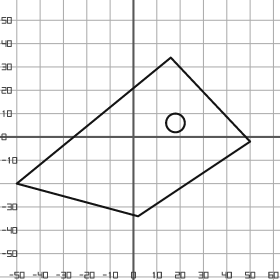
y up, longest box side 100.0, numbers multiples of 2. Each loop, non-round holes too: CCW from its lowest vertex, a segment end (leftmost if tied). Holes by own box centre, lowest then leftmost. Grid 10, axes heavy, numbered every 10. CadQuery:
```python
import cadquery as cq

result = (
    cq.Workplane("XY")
    .moveTo(2.0, -34.0)
    .lineTo(50.0, -2.0)
    .lineTo(16.0, 34.0)
    .lineTo(-50.0, -20.0)
    .close()
    .moveTo(18.0, 6.0)
    .circle(4.0)
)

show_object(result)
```